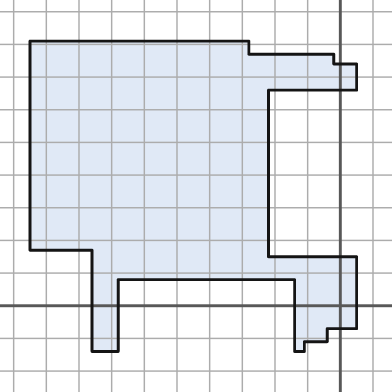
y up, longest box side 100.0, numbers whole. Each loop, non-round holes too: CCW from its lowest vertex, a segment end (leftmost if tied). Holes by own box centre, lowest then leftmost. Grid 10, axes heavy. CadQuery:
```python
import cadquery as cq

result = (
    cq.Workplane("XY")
    .moveTo(-76.0, -14.0)
    .lineTo(-68.0, -14.0)
    .lineTo(-68.0, 8.0)
    .lineTo(-14.0, 8.0)
    .lineTo(-14.0, -14.0)
    .lineTo(-11.0, -14.0)
    .lineTo(-11.0, -11.0)
    .lineTo(-4.0, -11.0)
    .lineTo(-4.0, -7.0)
    .lineTo(5.0, -7.0)
    .lineTo(5.0, 15.0)
    .lineTo(-22.0, 15.0)
    .lineTo(-22.0, 66.0)
    .lineTo(5.0, 66.0)
    .lineTo(5.0, 74.0)
    .lineTo(-2.0, 74.0)
    .lineTo(-2.0, 77.0)
    .lineTo(-28.0, 77.0)
    .lineTo(-28.0, 81.0)
    .lineTo(-95.0, 81.0)
    .lineTo(-95.0, 17.0)
    .lineTo(-76.0, 17.0)
    .close()
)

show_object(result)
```